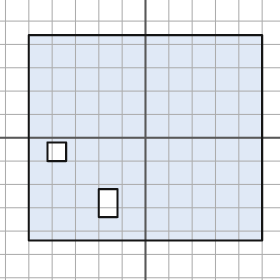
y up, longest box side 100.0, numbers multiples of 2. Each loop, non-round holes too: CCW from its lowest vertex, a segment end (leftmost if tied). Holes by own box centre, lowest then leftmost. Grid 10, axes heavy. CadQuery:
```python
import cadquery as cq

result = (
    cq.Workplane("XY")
    .moveTo(-50.0, -44.0)
    .lineTo(50.0, -44.0)
    .lineTo(50.0, 44.0)
    .lineTo(-50.0, 44.0)
    .close()
    .moveTo(-20.0, -34.0)
    .lineTo(-12.0, -34.0)
    .lineTo(-12.0, -22.0)
    .lineTo(-20.0, -22.0)
    .close()
    .moveTo(-42.0, -10.0)
    .lineTo(-34.0, -10.0)
    .lineTo(-34.0, -2.0)
    .lineTo(-42.0, -2.0)
    .close()
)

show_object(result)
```